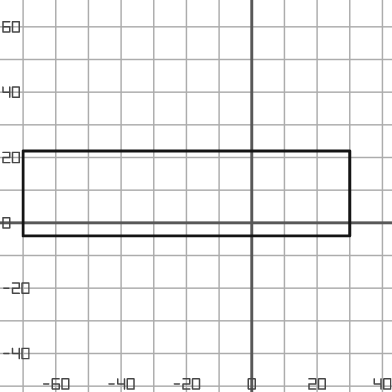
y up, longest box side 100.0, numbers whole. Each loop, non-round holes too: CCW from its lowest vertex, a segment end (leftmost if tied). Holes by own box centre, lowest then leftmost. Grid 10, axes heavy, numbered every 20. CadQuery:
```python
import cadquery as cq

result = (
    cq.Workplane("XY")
    .moveTo(-70.0, -4.0)
    .lineTo(30.0, -4.0)
    .lineTo(30.0, 22.0)
    .lineTo(-70.0, 22.0)
    .close()
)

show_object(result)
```